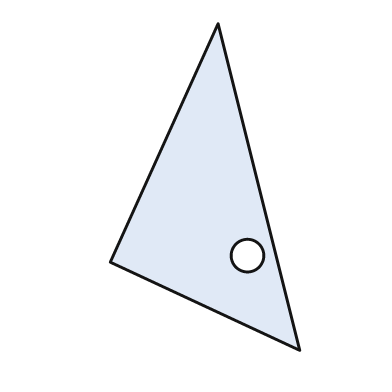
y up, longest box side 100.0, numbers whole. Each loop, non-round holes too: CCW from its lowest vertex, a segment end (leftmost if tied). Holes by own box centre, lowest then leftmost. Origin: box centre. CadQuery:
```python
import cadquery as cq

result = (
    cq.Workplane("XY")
    .moveTo(29.0, -50.0)
    .lineTo(4.0, 50.0)
    .lineTo(-29.0, -23.0)
    .close()
    .moveTo(13.0, -21.0)
    .circle(5.0)
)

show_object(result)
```